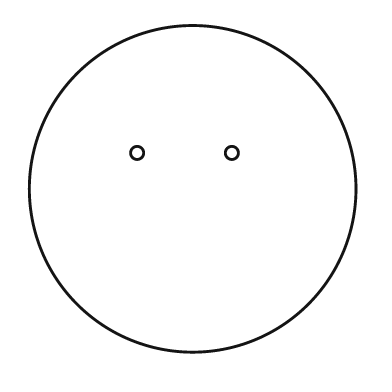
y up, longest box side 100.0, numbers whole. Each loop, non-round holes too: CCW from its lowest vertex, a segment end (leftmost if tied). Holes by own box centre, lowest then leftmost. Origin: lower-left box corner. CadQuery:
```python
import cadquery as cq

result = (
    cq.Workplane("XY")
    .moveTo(50.0, 50.0)
    .circle(50.0)
    .moveTo(33.0, 61.0)
    .circle(2.0)
    .moveTo(62.0, 61.0)
    .circle(2.0)
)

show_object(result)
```